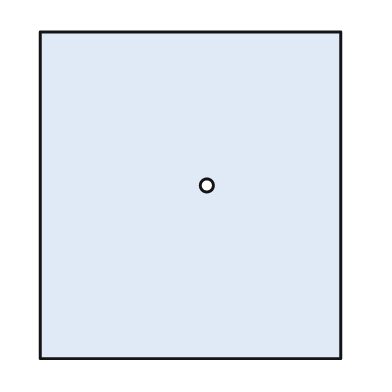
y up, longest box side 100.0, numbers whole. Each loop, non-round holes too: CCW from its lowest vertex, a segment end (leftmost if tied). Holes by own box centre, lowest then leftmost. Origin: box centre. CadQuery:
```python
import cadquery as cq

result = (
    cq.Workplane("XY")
    .moveTo(-46.0, -50.0)
    .lineTo(46.0, -50.0)
    .lineTo(46.0, 50.0)
    .lineTo(-46.0, 50.0)
    .close()
    .moveTo(5.0, 3.0)
    .circle(2.0)
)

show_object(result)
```